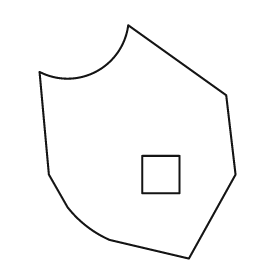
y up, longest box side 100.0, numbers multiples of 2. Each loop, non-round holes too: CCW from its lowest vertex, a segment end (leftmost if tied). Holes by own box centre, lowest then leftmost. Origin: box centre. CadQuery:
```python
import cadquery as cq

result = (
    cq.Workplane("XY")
    .moveTo(22.0, -50.0)
    .lineTo(42.0, -14.0)
    .lineTo(38.0, 20.0)
    .lineTo(-4.0, 50.0)
    .threePointArc((-18.0, 30.0), (-42.0, 30.0))
    .lineTo(-38.0, -14.0)
    .lineTo(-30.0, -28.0)
    .threePointArc((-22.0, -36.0), (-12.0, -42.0))
    .close()
    .moveTo(2.0, -22.0)
    .lineTo(18.0, -22.0)
    .lineTo(18.0, -6.0)
    .lineTo(2.0, -6.0)
    .close()
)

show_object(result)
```